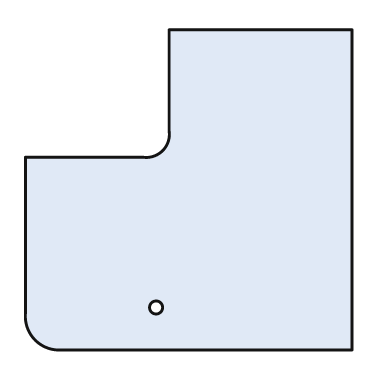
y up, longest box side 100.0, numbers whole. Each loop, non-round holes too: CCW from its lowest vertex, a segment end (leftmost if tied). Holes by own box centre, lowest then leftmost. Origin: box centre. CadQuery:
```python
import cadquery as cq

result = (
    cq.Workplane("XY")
    .moveTo(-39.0, -49.0)
    .lineTo(50.0, -49.0)
    .lineTo(50.0, 49.0)
    .lineTo(-6.0, 49.0)
    .lineTo(-6.0, 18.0)
    .threePointArc((-8.0, 12.0), (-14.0, 10.0))
    .lineTo(-50.0, 10.0)
    .lineTo(-50.0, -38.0)
    .threePointArc((-47.0, -46.0), (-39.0, -49.0))
    .close()
    .moveTo(-10.0, -36.0)
    .circle(2.0)
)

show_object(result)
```